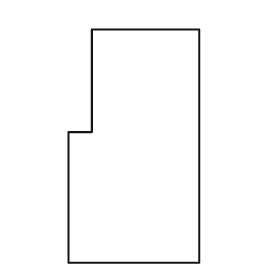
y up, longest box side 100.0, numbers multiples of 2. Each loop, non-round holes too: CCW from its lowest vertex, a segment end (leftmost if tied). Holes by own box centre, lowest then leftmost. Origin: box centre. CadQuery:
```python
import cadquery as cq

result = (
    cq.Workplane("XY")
    .moveTo(-28.0, -50.0)
    .lineTo(28.0, -50.0)
    .lineTo(28.0, 50.0)
    .lineTo(-18.0, 50.0)
    .lineTo(-18.0, 6.0)
    .lineTo(-28.0, 6.0)
    .close()
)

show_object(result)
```